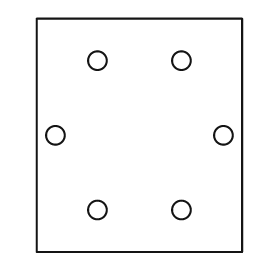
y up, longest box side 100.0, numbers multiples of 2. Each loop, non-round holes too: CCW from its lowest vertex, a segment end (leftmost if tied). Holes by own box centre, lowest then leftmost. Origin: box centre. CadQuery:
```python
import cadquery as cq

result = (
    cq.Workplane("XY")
    .moveTo(-44.0, -50.0)
    .lineTo(44.0, -50.0)
    .lineTo(44.0, 50.0)
    .lineTo(-44.0, 50.0)
    .close()
    .moveTo(-18.0, -32.0)
    .circle(4.0)
    .moveTo(18.0, -32.0)
    .circle(4.0)
    .moveTo(-36.0, 0.0)
    .circle(4.0)
    .moveTo(36.0, 0.0)
    .circle(4.0)
    .moveTo(-18.0, 32.0)
    .circle(4.0)
    .moveTo(18.0, 32.0)
    .circle(4.0)
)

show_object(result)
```